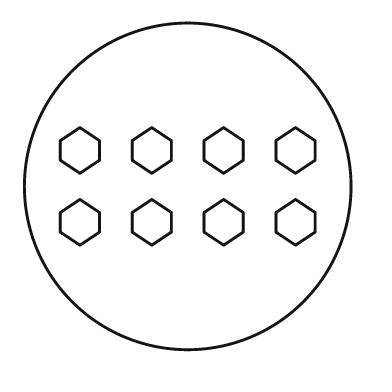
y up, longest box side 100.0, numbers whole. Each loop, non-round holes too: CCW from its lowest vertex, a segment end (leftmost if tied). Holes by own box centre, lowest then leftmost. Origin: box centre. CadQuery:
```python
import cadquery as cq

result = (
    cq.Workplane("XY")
    .moveTo(0.0, 0.0)
    .circle(50.0)
    .moveTo(-33.0, -18.0)
    .lineTo(-27.0, -14.0)
    .lineTo(-27.0, -8.0)
    .lineTo(-33.0, -4.0)
    .lineTo(-39.0, -8.0)
    .lineTo(-39.0, -14.0)
    .close()
    .moveTo(-11.0, -18.0)
    .lineTo(-5.0, -14.0)
    .lineTo(-5.0, -8.0)
    .lineTo(-11.0, -4.0)
    .lineTo(-17.0, -8.0)
    .lineTo(-17.0, -14.0)
    .close()
    .moveTo(11.0, -18.0)
    .lineTo(17.0, -14.0)
    .lineTo(17.0, -8.0)
    .lineTo(11.0, -4.0)
    .lineTo(5.0, -8.0)
    .lineTo(5.0, -14.0)
    .close()
    .moveTo(33.0, -18.0)
    .lineTo(39.0, -14.0)
    .lineTo(39.0, -8.0)
    .lineTo(33.0, -4.0)
    .lineTo(27.0, -8.0)
    .lineTo(27.0, -14.0)
    .close()
    .moveTo(-33.0, 4.0)
    .lineTo(-27.0, 8.0)
    .lineTo(-27.0, 14.0)
    .lineTo(-33.0, 18.0)
    .lineTo(-39.0, 14.0)
    .lineTo(-39.0, 8.0)
    .close()
    .moveTo(-11.0, 4.0)
    .lineTo(-5.0, 8.0)
    .lineTo(-5.0, 14.0)
    .lineTo(-11.0, 18.0)
    .lineTo(-17.0, 14.0)
    .lineTo(-17.0, 8.0)
    .close()
    .moveTo(11.0, 4.0)
    .lineTo(17.0, 8.0)
    .lineTo(17.0, 14.0)
    .lineTo(11.0, 18.0)
    .lineTo(5.0, 14.0)
    .lineTo(5.0, 8.0)
    .close()
    .moveTo(33.0, 4.0)
    .lineTo(39.0, 8.0)
    .lineTo(39.0, 14.0)
    .lineTo(33.0, 18.0)
    .lineTo(27.0, 14.0)
    .lineTo(27.0, 8.0)
    .close()
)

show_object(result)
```